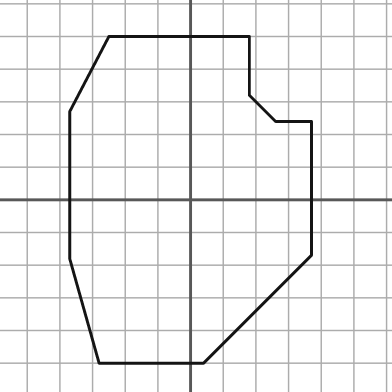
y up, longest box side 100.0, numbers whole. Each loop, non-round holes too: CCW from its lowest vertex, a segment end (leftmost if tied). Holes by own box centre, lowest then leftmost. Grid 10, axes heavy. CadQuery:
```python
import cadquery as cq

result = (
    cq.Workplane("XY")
    .moveTo(-28.0, -50.0)
    .lineTo(4.0, -50.0)
    .lineTo(37.0, -17.0)
    .lineTo(37.0, 24.0)
    .lineTo(26.0, 24.0)
    .lineTo(18.0, 32.0)
    .lineTo(18.0, 50.0)
    .lineTo(-25.0, 50.0)
    .lineTo(-37.0, 27.0)
    .lineTo(-37.0, -18.0)
    .close()
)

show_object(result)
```